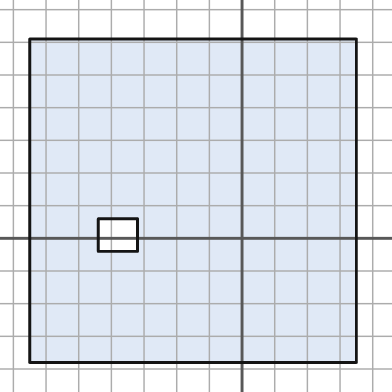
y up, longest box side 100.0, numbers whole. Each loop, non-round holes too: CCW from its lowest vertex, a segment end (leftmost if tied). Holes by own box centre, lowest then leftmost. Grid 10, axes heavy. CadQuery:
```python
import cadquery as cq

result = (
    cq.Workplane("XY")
    .moveTo(-65.0, -38.0)
    .lineTo(35.0, -38.0)
    .lineTo(35.0, 61.0)
    .lineTo(-65.0, 61.0)
    .close()
    .moveTo(-44.0, -4.0)
    .lineTo(-32.0, -4.0)
    .lineTo(-32.0, 6.0)
    .lineTo(-44.0, 6.0)
    .close()
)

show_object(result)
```